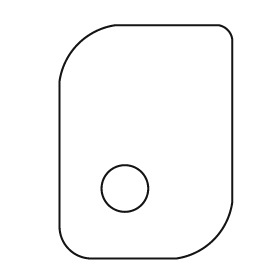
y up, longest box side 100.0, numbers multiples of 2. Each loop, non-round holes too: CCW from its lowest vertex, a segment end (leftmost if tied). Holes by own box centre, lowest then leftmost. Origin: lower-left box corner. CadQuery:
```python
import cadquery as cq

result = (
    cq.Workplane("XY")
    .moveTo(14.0, 0.0)
    .lineTo(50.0, 0.0)
    .threePointArc((66.0, 8.0), (74.0, 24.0))
    .lineTo(74.0, 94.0)
    .threePointArc((72.0, 98.0), (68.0, 100.0))
    .lineTo(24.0, 100.0)
    .threePointArc((8.0, 92.0), (0.0, 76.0))
    .lineTo(0.0, 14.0)
    .threePointArc((4.0, 4.0), (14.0, 0.0))
    .close()
    .moveTo(28.0, 30.0)
    .circle(10.0)
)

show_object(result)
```